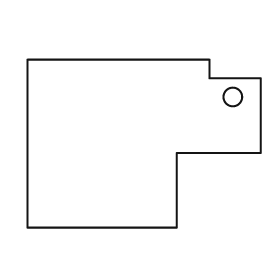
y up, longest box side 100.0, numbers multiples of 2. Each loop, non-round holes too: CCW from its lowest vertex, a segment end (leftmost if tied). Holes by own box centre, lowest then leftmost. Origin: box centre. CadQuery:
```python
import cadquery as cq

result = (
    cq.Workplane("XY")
    .moveTo(-50.0, -36.0)
    .lineTo(14.0, -36.0)
    .lineTo(14.0, -4.0)
    .lineTo(50.0, -4.0)
    .lineTo(50.0, 28.0)
    .lineTo(28.0, 28.0)
    .lineTo(28.0, 36.0)
    .lineTo(-50.0, 36.0)
    .close()
    .moveTo(38.0, 20.0)
    .circle(4.0)
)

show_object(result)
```